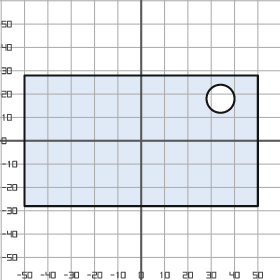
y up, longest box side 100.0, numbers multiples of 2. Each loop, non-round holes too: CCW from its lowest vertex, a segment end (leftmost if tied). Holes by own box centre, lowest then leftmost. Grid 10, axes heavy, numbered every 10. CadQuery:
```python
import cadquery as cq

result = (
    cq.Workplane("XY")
    .moveTo(-50.0, -28.0)
    .lineTo(50.0, -28.0)
    .lineTo(50.0, 28.0)
    .lineTo(-50.0, 28.0)
    .close()
    .moveTo(34.0, 18.0)
    .circle(6.0)
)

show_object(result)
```